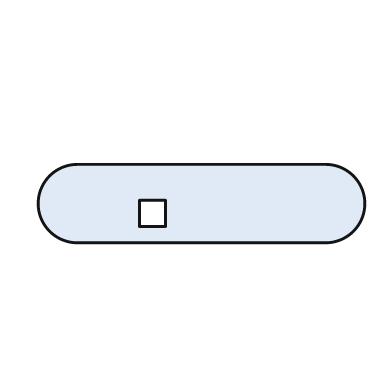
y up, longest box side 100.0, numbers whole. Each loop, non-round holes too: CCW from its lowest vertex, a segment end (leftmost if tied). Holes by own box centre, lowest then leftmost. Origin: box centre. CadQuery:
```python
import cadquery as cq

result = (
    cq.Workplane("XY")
    .moveTo(-38.0, -12.0)
    .lineTo(38.0, -12.0)
    .threePointArc((50.0, 0.0), (38.0, 12.0))
    .lineTo(-38.0, 12.0)
    .threePointArc((-50.0, 0.0), (-38.0, -12.0))
    .close()
    .moveTo(-19.0, -7.0)
    .lineTo(-11.0, -7.0)
    .lineTo(-11.0, 1.0)
    .lineTo(-19.0, 1.0)
    .close()
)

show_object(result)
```